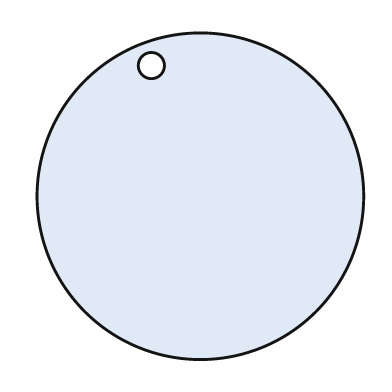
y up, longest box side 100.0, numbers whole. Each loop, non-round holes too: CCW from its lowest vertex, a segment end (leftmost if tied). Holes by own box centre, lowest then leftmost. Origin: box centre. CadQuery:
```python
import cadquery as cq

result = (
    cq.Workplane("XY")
    .moveTo(0.0, 0.0)
    .circle(50.0)
    .moveTo(-15.0, 40.0)
    .circle(4.0)
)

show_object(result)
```